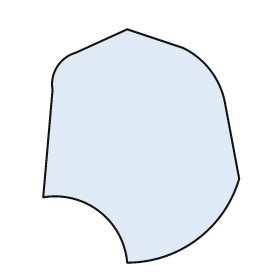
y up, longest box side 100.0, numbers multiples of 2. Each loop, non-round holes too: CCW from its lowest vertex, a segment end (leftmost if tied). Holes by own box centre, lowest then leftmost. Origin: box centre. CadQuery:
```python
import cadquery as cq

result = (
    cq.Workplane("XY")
    .moveTo(-6.0, -50.0)
    .threePointArc((24.0, -40.0), (42.0, -14.0))
    .lineTo(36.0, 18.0)
    .threePointArc((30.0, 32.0), (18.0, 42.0))
    .lineTo(-6.0, 50.0)
    .lineTo(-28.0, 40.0)
    .threePointArc((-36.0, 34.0), (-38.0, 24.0))
    .lineTo(-42.0, -22.0)
    .threePointArc((-18.0, -28.0), (-6.0, -50.0))
    .close()
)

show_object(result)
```